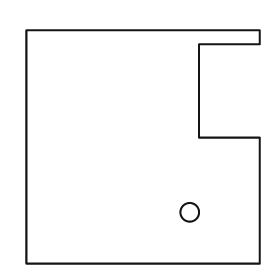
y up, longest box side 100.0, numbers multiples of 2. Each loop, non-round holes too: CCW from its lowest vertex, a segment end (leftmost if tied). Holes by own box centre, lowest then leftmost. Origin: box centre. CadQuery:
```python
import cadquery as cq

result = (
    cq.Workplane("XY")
    .moveTo(-50.0, -50.0)
    .lineTo(50.0, -50.0)
    .lineTo(50.0, 4.0)
    .lineTo(24.0, 4.0)
    .lineTo(24.0, 44.0)
    .lineTo(50.0, 44.0)
    .lineTo(50.0, 50.0)
    .lineTo(-50.0, 50.0)
    .close()
    .moveTo(20.0, -28.0)
    .circle(4.0)
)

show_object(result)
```